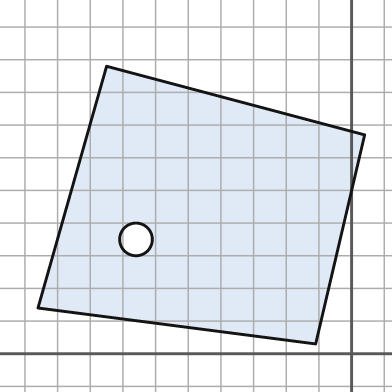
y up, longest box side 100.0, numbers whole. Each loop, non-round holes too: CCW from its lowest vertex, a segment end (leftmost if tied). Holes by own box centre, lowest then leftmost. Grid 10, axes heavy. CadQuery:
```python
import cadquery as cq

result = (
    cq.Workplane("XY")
    .moveTo(-11.0, 3.0)
    .lineTo(4.0, 67.0)
    .lineTo(-75.0, 88.0)
    .lineTo(-96.0, 14.0)
    .close()
    .moveTo(-66.0, 35.0)
    .circle(5.0)
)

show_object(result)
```